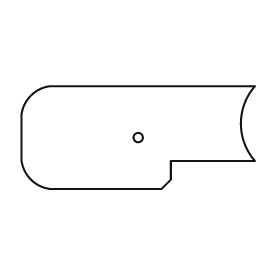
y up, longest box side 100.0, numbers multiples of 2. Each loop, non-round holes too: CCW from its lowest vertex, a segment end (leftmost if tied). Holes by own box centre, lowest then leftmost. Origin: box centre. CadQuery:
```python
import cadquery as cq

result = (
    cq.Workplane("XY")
    .moveTo(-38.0, -22.0)
    .lineTo(10.0, -22.0)
    .lineTo(14.0, -18.0)
    .lineTo(14.0, -10.0)
    .lineTo(50.0, -10.0)
    .threePointArc((44.0, 6.0), (50.0, 22.0))
    .lineTo(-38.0, 22.0)
    .threePointArc((-46.0, 18.0), (-50.0, 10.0))
    .lineTo(-50.0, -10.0)
    .threePointArc((-46.0, -18.0), (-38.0, -22.0))
    .close()
    .moveTo(0.0, 0.0)
    .circle(2.0)
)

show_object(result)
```